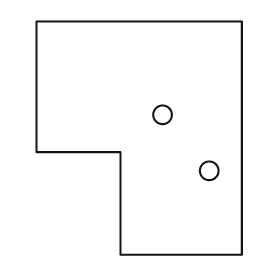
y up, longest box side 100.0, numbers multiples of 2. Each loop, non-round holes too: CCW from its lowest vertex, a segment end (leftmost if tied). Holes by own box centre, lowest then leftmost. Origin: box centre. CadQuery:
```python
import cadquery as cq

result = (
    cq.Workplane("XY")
    .moveTo(-8.0, -50.0)
    .lineTo(44.0, -50.0)
    .lineTo(44.0, 50.0)
    .lineTo(-44.0, 50.0)
    .lineTo(-44.0, -6.0)
    .lineTo(-8.0, -6.0)
    .close()
    .moveTo(30.0, -14.0)
    .circle(4.0)
    .moveTo(10.0, 10.0)
    .circle(4.0)
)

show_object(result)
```